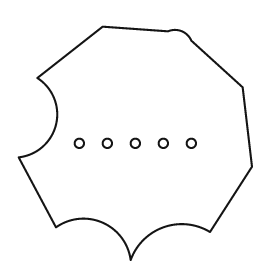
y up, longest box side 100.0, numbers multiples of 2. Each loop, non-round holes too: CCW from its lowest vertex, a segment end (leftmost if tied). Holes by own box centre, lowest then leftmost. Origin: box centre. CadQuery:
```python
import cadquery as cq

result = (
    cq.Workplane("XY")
    .moveTo(-2.0, -50.0)
    .threePointArc((12.0, -36.0), (32.0, -38.0))
    .lineTo(50.0, -10.0)
    .lineTo(46.0, 24.0)
    .lineTo(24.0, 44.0)
    .threePointArc((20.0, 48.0), (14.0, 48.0))
    .lineTo(-14.0, 50.0)
    .lineTo(-42.0, 28.0)
    .threePointArc((-34.0, 8.0), (-50.0, -6.0))
    .lineTo(-34.0, -36.0)
    .threePointArc((-14.0, -34.0), (-2.0, -50.0))
    .close()
    .moveTo(-24.0, 0.0)
    .circle(2.0)
    .moveTo(-12.0, 0.0)
    .circle(2.0)
    .moveTo(0.0, 0.0)
    .circle(2.0)
    .moveTo(12.0, 0.0)
    .circle(2.0)
    .moveTo(24.0, 0.0)
    .circle(2.0)
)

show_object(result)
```